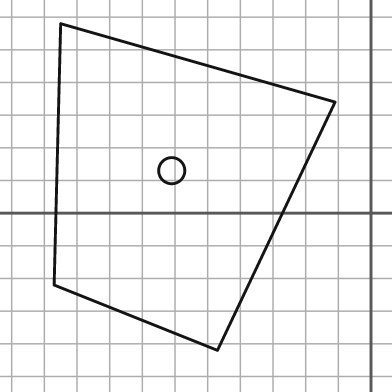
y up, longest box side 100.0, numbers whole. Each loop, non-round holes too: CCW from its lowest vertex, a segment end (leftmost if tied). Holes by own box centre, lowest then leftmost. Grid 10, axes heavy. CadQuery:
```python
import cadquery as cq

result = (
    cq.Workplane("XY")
    .moveTo(-47.0, -42.0)
    .lineTo(-11.0, 34.0)
    .lineTo(-95.0, 58.0)
    .lineTo(-97.0, -22.0)
    .close()
    .moveTo(-61.0, 13.0)
    .circle(4.0)
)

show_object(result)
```